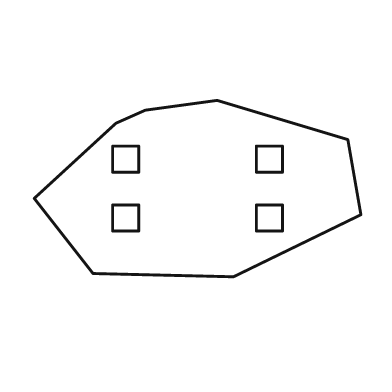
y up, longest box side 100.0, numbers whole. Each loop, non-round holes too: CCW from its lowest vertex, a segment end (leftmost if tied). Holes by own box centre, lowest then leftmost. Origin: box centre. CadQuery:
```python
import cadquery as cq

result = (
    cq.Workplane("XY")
    .moveTo(11.0, -27.0)
    .lineTo(50.0, -8.0)
    .lineTo(46.0, 15.0)
    .lineTo(6.0, 27.0)
    .lineTo(-16.0, 24.0)
    .lineTo(-25.0, 20.0)
    .lineTo(-50.0, -3.0)
    .lineTo(-32.0, -26.0)
    .close()
    .moveTo(-26.0, -13.0)
    .lineTo(-18.0, -13.0)
    .lineTo(-18.0, -5.0)
    .lineTo(-26.0, -5.0)
    .close()
    .moveTo(18.0, -13.0)
    .lineTo(26.0, -13.0)
    .lineTo(26.0, -5.0)
    .lineTo(18.0, -5.0)
    .close()
    .moveTo(-26.0, 5.0)
    .lineTo(-18.0, 5.0)
    .lineTo(-18.0, 13.0)
    .lineTo(-26.0, 13.0)
    .close()
    .moveTo(18.0, 5.0)
    .lineTo(26.0, 5.0)
    .lineTo(26.0, 13.0)
    .lineTo(18.0, 13.0)
    .close()
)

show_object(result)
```